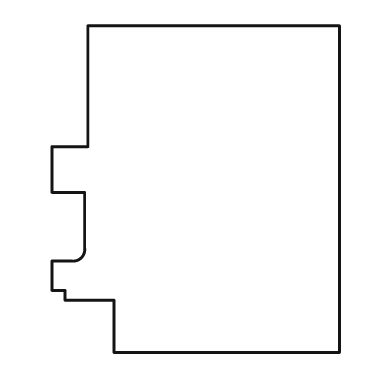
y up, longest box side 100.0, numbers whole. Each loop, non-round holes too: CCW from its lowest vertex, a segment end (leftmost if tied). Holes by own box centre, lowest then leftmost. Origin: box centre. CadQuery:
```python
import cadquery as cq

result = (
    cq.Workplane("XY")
    .moveTo(-25.0, -50.0)
    .lineTo(44.0, -50.0)
    .lineTo(44.0, 50.0)
    .lineTo(-33.0, 50.0)
    .lineTo(-33.0, 13.0)
    .lineTo(-44.0, 13.0)
    .lineTo(-44.0, -1.0)
    .lineTo(-34.0, -1.0)
    .lineTo(-34.0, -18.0)
    .threePointArc((-35.0, -21.0), (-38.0, -22.0))
    .lineTo(-44.0, -22.0)
    .lineTo(-44.0, -31.0)
    .lineTo(-40.0, -31.0)
    .lineTo(-40.0, -34.0)
    .lineTo(-25.0, -34.0)
    .close()
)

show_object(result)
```